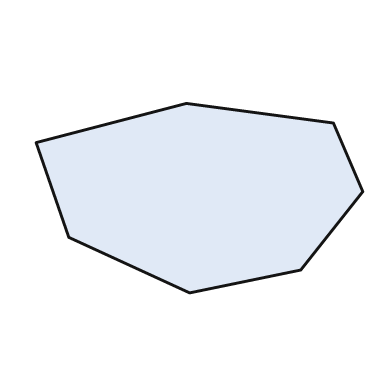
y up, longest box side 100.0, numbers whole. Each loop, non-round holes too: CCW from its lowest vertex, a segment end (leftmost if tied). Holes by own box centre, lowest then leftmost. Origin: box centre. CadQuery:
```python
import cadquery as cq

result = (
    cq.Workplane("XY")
    .moveTo(-3.0, -29.0)
    .lineTo(31.0, -22.0)
    .lineTo(50.0, 2.0)
    .lineTo(41.0, 23.0)
    .lineTo(-4.0, 29.0)
    .lineTo(-50.0, 17.0)
    .lineTo(-40.0, -12.0)
    .close()
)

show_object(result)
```